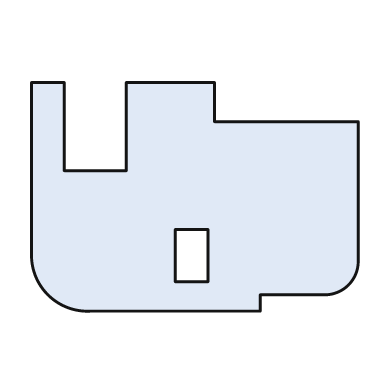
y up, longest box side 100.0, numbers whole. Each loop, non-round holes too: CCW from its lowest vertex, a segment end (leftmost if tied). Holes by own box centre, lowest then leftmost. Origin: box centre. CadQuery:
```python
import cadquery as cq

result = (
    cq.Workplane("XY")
    .moveTo(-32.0, -35.0)
    .lineTo(20.0, -35.0)
    .lineTo(20.0, -30.0)
    .lineTo(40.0, -30.0)
    .threePointArc((47.0, -27.0), (50.0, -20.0))
    .lineTo(50.0, 23.0)
    .lineTo(6.0, 23.0)
    .lineTo(6.0, 35.0)
    .lineTo(-21.0, 35.0)
    .lineTo(-21.0, 8.0)
    .lineTo(-40.0, 8.0)
    .lineTo(-40.0, 35.0)
    .lineTo(-50.0, 35.0)
    .lineTo(-50.0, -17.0)
    .threePointArc((-45.0, -30.0), (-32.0, -35.0))
    .close()
    .moveTo(-6.0, -26.0)
    .lineTo(4.0, -26.0)
    .lineTo(4.0, -10.0)
    .lineTo(-6.0, -10.0)
    .close()
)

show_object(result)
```